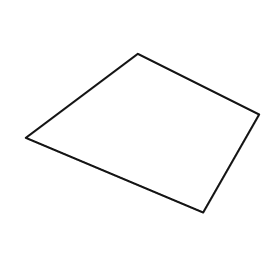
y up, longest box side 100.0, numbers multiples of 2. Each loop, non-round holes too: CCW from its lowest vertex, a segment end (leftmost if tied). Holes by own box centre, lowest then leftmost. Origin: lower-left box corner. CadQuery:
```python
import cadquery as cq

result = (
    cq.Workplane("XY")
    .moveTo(76.0, 0.0)
    .lineTo(100.0, 42.0)
    .lineTo(48.0, 68.0)
    .lineTo(0.0, 32.0)
    .close()
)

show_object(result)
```